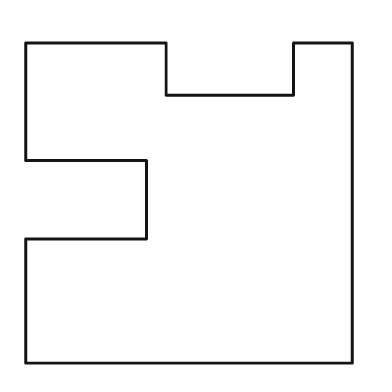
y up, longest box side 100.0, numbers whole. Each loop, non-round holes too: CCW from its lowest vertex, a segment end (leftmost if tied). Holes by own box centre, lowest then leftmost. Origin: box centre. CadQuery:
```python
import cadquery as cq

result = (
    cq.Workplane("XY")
    .moveTo(-50.0, -49.0)
    .lineTo(50.0, -49.0)
    .lineTo(50.0, 49.0)
    .lineTo(32.0, 49.0)
    .lineTo(32.0, 33.0)
    .lineTo(-7.0, 33.0)
    .lineTo(-7.0, 49.0)
    .lineTo(-50.0, 49.0)
    .lineTo(-50.0, 13.0)
    .lineTo(-13.0, 13.0)
    .lineTo(-13.0, -11.0)
    .lineTo(-50.0, -11.0)
    .close()
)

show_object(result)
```